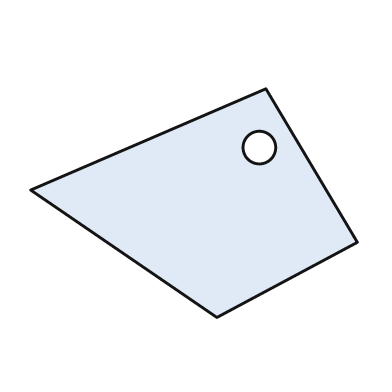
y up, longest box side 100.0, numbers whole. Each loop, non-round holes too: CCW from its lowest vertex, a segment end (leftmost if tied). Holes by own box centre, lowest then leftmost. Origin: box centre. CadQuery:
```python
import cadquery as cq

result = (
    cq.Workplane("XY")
    .moveTo(7.0, -35.0)
    .lineTo(50.0, -12.0)
    .lineTo(22.0, 35.0)
    .lineTo(-50.0, 4.0)
    .close()
    .moveTo(20.0, 17.0)
    .circle(5.0)
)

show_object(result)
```